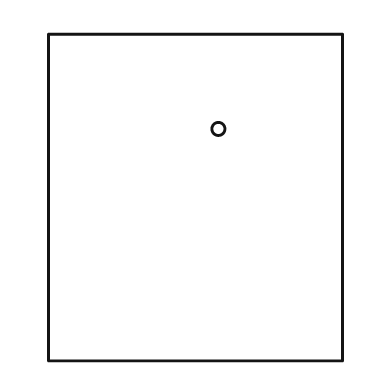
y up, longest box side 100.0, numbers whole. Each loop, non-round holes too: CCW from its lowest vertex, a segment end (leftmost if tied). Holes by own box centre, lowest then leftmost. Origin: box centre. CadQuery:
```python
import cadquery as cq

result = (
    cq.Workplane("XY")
    .moveTo(-45.0, -50.0)
    .lineTo(45.0, -50.0)
    .lineTo(45.0, 50.0)
    .lineTo(-45.0, 50.0)
    .close()
    .moveTo(7.0, 21.0)
    .circle(2.0)
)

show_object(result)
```